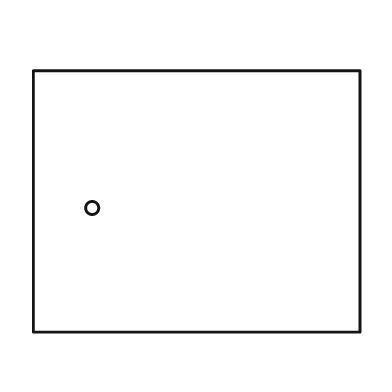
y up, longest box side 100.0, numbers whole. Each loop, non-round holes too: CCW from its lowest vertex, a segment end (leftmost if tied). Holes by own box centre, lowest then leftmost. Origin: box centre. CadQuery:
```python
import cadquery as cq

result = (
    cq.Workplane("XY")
    .moveTo(-50.0, -40.0)
    .lineTo(50.0, -40.0)
    .lineTo(50.0, 40.0)
    .lineTo(-50.0, 40.0)
    .close()
    .moveTo(-32.0, -2.0)
    .circle(2.0)
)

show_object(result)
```